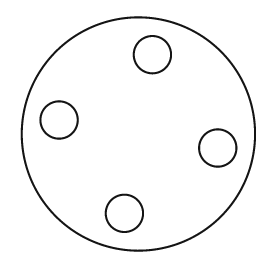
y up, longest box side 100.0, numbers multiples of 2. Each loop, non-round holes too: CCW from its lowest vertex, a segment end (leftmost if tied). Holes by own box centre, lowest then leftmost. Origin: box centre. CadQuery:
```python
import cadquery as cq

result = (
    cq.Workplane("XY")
    .moveTo(0.0, 0.0)
    .circle(50.0)
    .moveTo(-6.0, -34.0)
    .circle(8.0)
    .moveTo(34.0, -6.0)
    .circle(8.0)
    .moveTo(-34.0, 6.0)
    .circle(8.0)
    .moveTo(6.0, 34.0)
    .circle(8.0)
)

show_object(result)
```